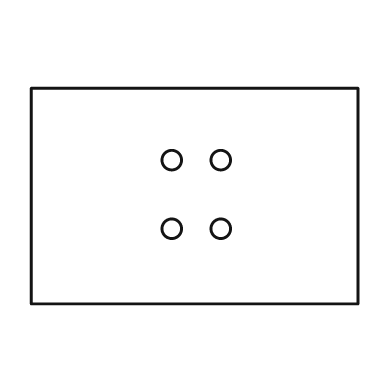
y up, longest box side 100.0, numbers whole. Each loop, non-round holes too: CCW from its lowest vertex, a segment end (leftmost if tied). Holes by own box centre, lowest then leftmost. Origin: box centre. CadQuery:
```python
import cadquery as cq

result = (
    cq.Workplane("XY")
    .moveTo(-50.0, -33.0)
    .lineTo(50.0, -33.0)
    .lineTo(50.0, 33.0)
    .lineTo(-50.0, 33.0)
    .close()
    .moveTo(-7.0, -10.0)
    .circle(3.0)
    .moveTo(8.0, -10.0)
    .circle(3.0)
    .moveTo(-7.0, 11.0)
    .circle(3.0)
    .moveTo(8.0, 11.0)
    .circle(3.0)
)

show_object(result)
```